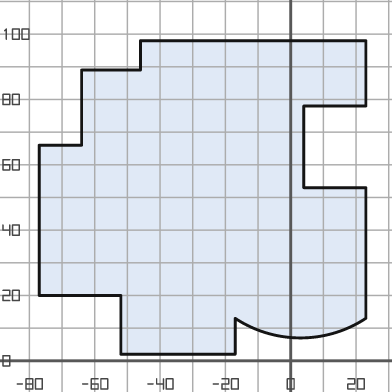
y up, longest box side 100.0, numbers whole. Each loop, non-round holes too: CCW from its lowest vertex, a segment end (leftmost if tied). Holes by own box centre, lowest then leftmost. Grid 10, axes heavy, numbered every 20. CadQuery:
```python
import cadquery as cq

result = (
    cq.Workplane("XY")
    .moveTo(-52.0, 2.0)
    .lineTo(-17.0, 2.0)
    .lineTo(-17.0, 13.0)
    .threePointArc((3.0, 7.0), (23.0, 13.0))
    .lineTo(23.0, 53.0)
    .lineTo(4.0, 53.0)
    .lineTo(4.0, 78.0)
    .lineTo(23.0, 78.0)
    .lineTo(23.0, 98.0)
    .lineTo(-46.0, 98.0)
    .lineTo(-46.0, 89.0)
    .lineTo(-64.0, 89.0)
    .lineTo(-64.0, 66.0)
    .lineTo(-77.0, 66.0)
    .lineTo(-77.0, 20.0)
    .lineTo(-52.0, 20.0)
    .close()
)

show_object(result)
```